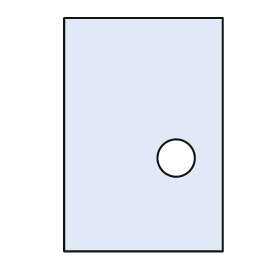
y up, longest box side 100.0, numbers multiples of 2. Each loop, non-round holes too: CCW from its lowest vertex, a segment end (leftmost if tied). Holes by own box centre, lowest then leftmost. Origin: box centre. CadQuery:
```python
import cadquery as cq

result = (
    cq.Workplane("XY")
    .moveTo(-34.0, -50.0)
    .lineTo(34.0, -50.0)
    .lineTo(34.0, 50.0)
    .lineTo(-34.0, 50.0)
    .close()
    .moveTo(14.0, -10.0)
    .circle(8.0)
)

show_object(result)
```